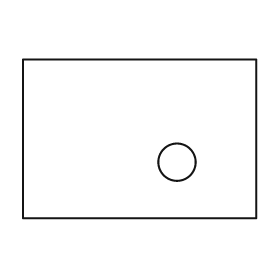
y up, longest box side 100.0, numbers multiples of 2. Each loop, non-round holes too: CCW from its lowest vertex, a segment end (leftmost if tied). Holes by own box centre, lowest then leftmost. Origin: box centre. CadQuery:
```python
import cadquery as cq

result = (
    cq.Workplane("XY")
    .moveTo(-50.0, -34.0)
    .lineTo(50.0, -34.0)
    .lineTo(50.0, 34.0)
    .lineTo(-50.0, 34.0)
    .close()
    .moveTo(16.0, -10.0)
    .circle(8.0)
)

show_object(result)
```